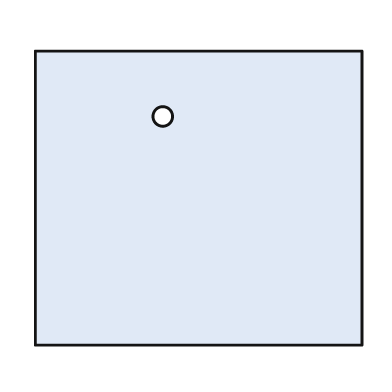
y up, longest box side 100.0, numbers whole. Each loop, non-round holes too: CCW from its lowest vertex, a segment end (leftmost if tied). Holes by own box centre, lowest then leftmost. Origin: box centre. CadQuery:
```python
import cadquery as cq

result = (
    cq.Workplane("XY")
    .moveTo(-50.0, -45.0)
    .lineTo(50.0, -45.0)
    .lineTo(50.0, 45.0)
    .lineTo(-50.0, 45.0)
    .close()
    .moveTo(-11.0, 25.0)
    .circle(3.0)
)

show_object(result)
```